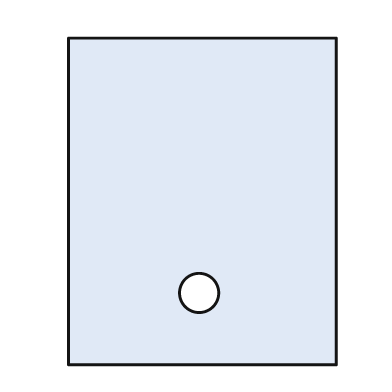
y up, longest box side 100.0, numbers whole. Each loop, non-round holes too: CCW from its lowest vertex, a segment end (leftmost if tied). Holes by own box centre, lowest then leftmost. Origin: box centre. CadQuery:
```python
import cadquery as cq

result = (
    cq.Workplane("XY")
    .moveTo(-41.0, -50.0)
    .lineTo(41.0, -50.0)
    .lineTo(41.0, 50.0)
    .lineTo(-41.0, 50.0)
    .close()
    .moveTo(-1.0, -28.0)
    .circle(6.0)
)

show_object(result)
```